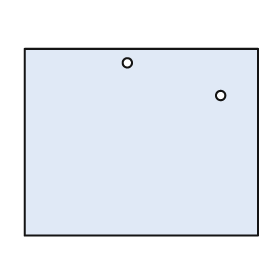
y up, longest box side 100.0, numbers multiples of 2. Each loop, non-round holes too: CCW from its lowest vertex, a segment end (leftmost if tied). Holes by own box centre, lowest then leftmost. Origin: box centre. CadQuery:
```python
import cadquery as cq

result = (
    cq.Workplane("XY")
    .moveTo(-50.0, -40.0)
    .lineTo(50.0, -40.0)
    .lineTo(50.0, 40.0)
    .lineTo(-50.0, 40.0)
    .close()
    .moveTo(34.0, 20.0)
    .circle(2.0)
    .moveTo(-6.0, 34.0)
    .circle(2.0)
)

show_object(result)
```